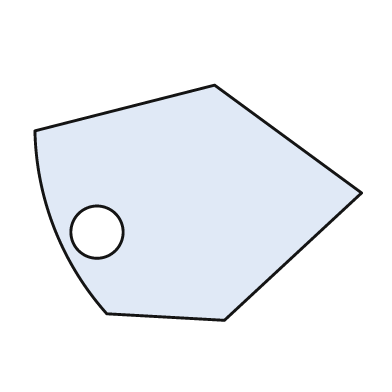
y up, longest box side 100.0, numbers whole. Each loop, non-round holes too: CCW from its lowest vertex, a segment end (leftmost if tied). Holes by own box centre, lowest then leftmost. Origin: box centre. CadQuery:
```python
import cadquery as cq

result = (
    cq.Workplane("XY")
    .moveTo(8.0, -36.0)
    .lineTo(50.0, 3.0)
    .lineTo(5.0, 36.0)
    .lineTo(-50.0, 22.0)
    .threePointArc((-44.0, -8.0), (-28.0, -34.0))
    .close()
    .moveTo(-31.0, -9.0)
    .circle(8.0)
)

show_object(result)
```